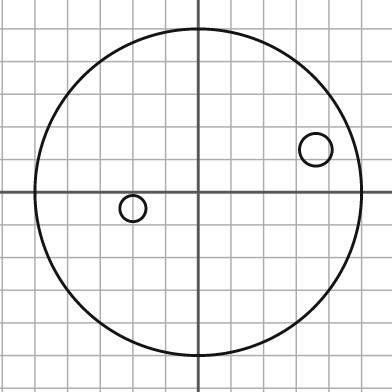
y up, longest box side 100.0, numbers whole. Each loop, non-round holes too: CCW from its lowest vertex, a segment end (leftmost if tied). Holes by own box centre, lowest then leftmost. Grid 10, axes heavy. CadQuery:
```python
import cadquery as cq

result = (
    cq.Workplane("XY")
    .moveTo(0.0, 0.0)
    .circle(50.0)
    .moveTo(-20.0, -5.0)
    .circle(4.0)
    .moveTo(36.0, 13.0)
    .circle(5.0)
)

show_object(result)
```